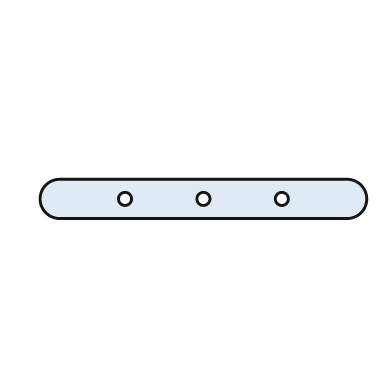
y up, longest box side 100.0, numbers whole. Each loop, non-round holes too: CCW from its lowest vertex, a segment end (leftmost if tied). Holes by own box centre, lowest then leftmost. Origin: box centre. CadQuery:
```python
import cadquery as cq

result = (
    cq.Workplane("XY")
    .moveTo(-44.0, -6.0)
    .lineTo(44.0, -6.0)
    .threePointArc((50.0, 0.0), (44.0, 6.0))
    .lineTo(-44.0, 6.0)
    .threePointArc((-50.0, 0.0), (-44.0, -6.0))
    .close()
    .moveTo(-24.0, 0.0)
    .circle(2.0)
    .moveTo(0.0, 0.0)
    .circle(2.0)
    .moveTo(24.0, 0.0)
    .circle(2.0)
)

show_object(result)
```